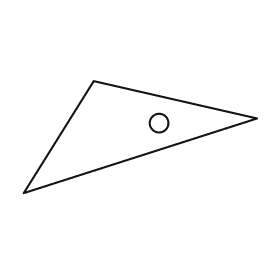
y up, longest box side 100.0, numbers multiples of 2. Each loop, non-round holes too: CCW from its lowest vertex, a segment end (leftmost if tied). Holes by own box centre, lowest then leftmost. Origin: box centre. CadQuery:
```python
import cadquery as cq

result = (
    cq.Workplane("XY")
    .moveTo(-50.0, -24.0)
    .lineTo(50.0, 8.0)
    .lineTo(-20.0, 24.0)
    .close()
    .moveTo(8.0, 6.0)
    .circle(4.0)
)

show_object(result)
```